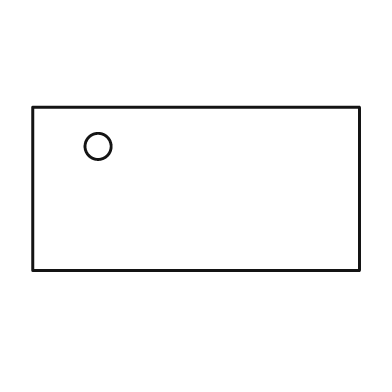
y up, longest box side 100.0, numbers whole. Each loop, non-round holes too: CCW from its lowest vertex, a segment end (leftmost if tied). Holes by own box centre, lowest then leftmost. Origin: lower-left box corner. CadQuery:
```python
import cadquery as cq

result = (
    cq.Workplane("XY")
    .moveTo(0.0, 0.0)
    .lineTo(100.0, 0.0)
    .lineTo(100.0, 50.0)
    .lineTo(0.0, 50.0)
    .close()
    .moveTo(20.0, 38.0)
    .circle(4.0)
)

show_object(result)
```